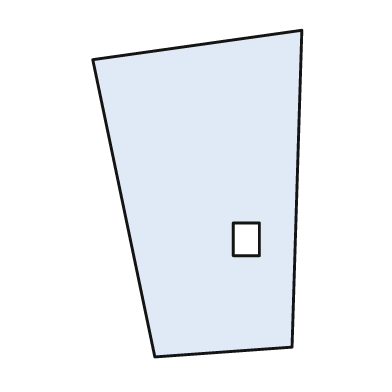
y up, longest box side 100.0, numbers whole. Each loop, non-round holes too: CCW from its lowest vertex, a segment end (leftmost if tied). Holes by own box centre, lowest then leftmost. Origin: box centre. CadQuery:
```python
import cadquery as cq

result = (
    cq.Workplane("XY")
    .moveTo(-13.0, -50.0)
    .lineTo(29.0, -47.0)
    .lineTo(32.0, 50.0)
    .lineTo(-32.0, 41.0)
    .close()
    .moveTo(11.0, -19.0)
    .lineTo(19.0, -19.0)
    .lineTo(19.0, -9.0)
    .lineTo(11.0, -9.0)
    .close()
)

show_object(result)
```